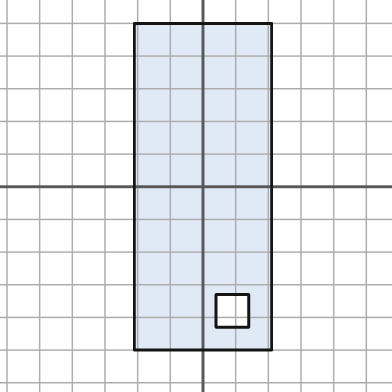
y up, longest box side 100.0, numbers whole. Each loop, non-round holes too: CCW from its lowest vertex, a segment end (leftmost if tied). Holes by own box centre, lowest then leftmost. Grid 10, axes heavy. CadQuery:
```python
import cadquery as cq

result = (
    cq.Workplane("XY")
    .moveTo(-21.0, -50.0)
    .lineTo(21.0, -50.0)
    .lineTo(21.0, 50.0)
    .lineTo(-21.0, 50.0)
    .close()
    .moveTo(4.0, -43.0)
    .lineTo(14.0, -43.0)
    .lineTo(14.0, -33.0)
    .lineTo(4.0, -33.0)
    .close()
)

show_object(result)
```